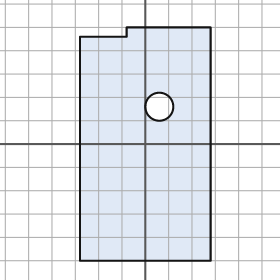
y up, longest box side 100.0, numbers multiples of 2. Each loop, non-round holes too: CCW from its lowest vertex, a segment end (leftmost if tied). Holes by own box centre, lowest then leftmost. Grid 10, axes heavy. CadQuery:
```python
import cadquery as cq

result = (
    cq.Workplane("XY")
    .moveTo(-28.0, -50.0)
    .lineTo(28.0, -50.0)
    .lineTo(28.0, 50.0)
    .lineTo(-8.0, 50.0)
    .lineTo(-8.0, 46.0)
    .lineTo(-28.0, 46.0)
    .close()
    .moveTo(6.0, 16.0)
    .circle(6.0)
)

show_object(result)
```